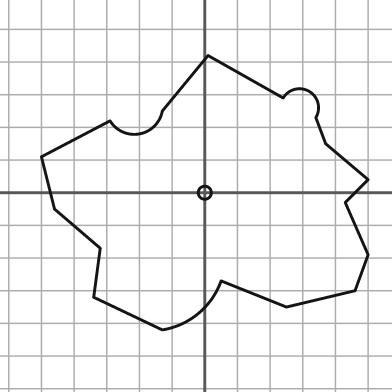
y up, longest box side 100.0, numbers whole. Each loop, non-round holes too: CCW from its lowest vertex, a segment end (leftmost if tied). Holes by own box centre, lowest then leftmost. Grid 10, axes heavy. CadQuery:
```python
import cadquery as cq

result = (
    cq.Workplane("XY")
    .moveTo(-13.0, -42.0)
    .threePointArc((-2.0, -37.0), (5.0, -27.0))
    .lineTo(25.0, -35.0)
    .lineTo(46.0, -30.0)
    .lineTo(50.0, -19.0)
    .lineTo(43.0, -3.0)
    .lineTo(50.0, 4.0)
    .lineTo(37.0, 15.0)
    .lineTo(34.0, 23.0)
    .threePointArc((32.0, 31.0), (24.0, 29.0))
    .lineTo(1.0, 42.0)
    .lineTo(-13.0, 25.0)
    .threePointArc((-20.0, 18.0), (-29.0, 22.0))
    .lineTo(-50.0, 11.0)
    .lineTo(-46.0, -5.0)
    .lineTo(-32.0, -17.0)
    .lineTo(-34.0, -32.0)
    .close()
    .moveTo(0.0, 0.0)
    .circle(2.0)
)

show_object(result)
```